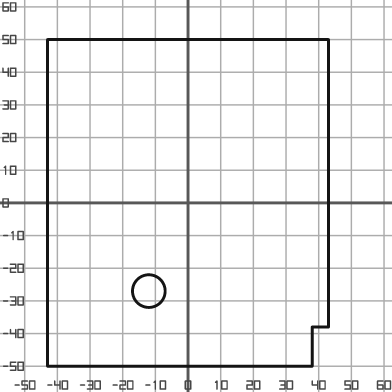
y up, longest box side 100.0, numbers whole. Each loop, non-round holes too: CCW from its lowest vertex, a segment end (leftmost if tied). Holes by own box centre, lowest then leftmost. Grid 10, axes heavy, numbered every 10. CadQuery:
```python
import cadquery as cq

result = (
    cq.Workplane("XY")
    .moveTo(-43.0, -50.0)
    .lineTo(38.0, -50.0)
    .lineTo(38.0, -38.0)
    .lineTo(43.0, -38.0)
    .lineTo(43.0, 50.0)
    .lineTo(-43.0, 50.0)
    .close()
    .moveTo(-12.0, -27.0)
    .circle(5.0)
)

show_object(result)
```